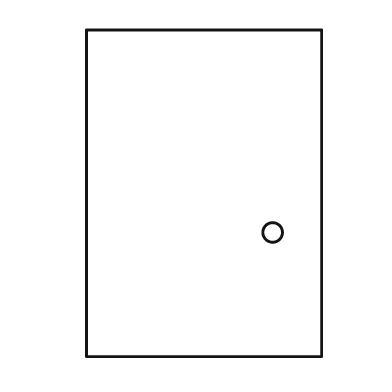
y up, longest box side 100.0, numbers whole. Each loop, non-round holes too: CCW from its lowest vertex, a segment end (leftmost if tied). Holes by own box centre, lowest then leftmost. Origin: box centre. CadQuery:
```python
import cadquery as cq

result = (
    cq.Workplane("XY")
    .moveTo(-36.0, -50.0)
    .lineTo(36.0, -50.0)
    .lineTo(36.0, 50.0)
    .lineTo(-36.0, 50.0)
    .close()
    .moveTo(21.0, -12.0)
    .circle(3.0)
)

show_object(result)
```